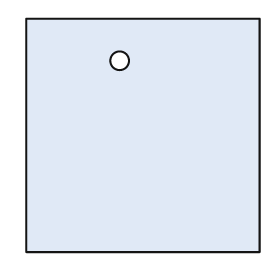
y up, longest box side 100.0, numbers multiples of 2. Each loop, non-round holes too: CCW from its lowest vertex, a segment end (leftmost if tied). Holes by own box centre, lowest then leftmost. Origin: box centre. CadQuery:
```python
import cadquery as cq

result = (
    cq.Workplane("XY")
    .moveTo(-50.0, -50.0)
    .lineTo(50.0, -50.0)
    .lineTo(50.0, 50.0)
    .lineTo(-50.0, 50.0)
    .close()
    .moveTo(-10.0, 32.0)
    .circle(4.0)
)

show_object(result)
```